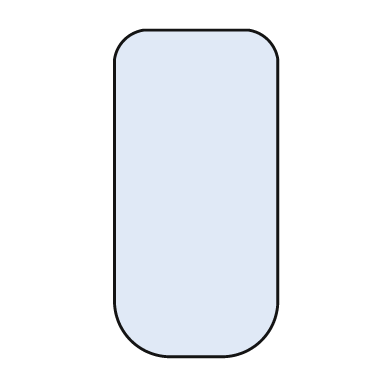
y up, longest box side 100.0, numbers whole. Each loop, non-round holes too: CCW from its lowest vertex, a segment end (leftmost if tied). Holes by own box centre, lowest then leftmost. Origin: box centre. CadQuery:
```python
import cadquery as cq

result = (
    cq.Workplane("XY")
    .moveTo(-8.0, -50.0)
    .lineTo(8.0, -50.0)
    .threePointArc((20.0, -45.0), (25.0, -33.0))
    .lineTo(25.0, 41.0)
    .threePointArc((22.0, 47.0), (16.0, 50.0))
    .lineTo(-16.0, 50.0)
    .threePointArc((-22.0, 47.0), (-25.0, 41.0))
    .lineTo(-25.0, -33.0)
    .threePointArc((-20.0, -45.0), (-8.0, -50.0))
    .close()
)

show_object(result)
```